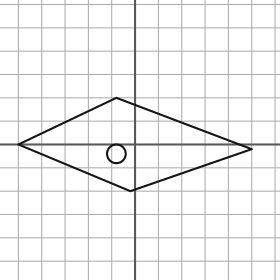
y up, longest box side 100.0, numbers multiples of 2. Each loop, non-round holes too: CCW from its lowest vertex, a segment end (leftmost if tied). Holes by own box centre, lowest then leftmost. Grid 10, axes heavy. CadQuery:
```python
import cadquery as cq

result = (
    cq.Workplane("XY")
    .moveTo(-2.0, -20.0)
    .lineTo(50.0, -2.0)
    .lineTo(-8.0, 20.0)
    .lineTo(-50.0, 0.0)
    .close()
    .moveTo(-8.0, -4.0)
    .circle(4.0)
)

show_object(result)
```